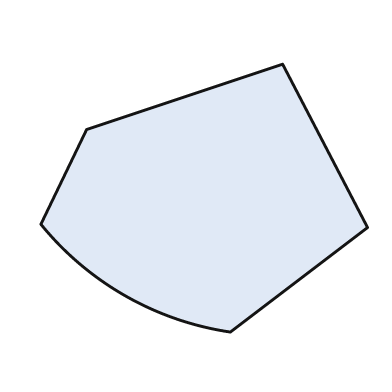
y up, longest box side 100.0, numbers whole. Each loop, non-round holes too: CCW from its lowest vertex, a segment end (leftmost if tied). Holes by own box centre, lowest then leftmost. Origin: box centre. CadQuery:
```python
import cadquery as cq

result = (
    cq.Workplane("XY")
    .moveTo(8.0, -41.0)
    .lineTo(50.0, -9.0)
    .lineTo(24.0, 41.0)
    .lineTo(-36.0, 21.0)
    .lineTo(-50.0, -8.0)
    .threePointArc((-24.0, -30.0), (8.0, -41.0))
    .close()
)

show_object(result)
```